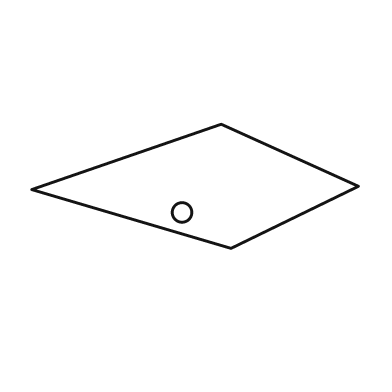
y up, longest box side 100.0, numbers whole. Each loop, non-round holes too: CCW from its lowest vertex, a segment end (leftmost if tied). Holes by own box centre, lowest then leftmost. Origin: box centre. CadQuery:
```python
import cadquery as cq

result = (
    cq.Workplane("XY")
    .moveTo(11.0, -19.0)
    .lineTo(50.0, 0.0)
    .lineTo(8.0, 19.0)
    .lineTo(-50.0, -1.0)
    .close()
    .moveTo(-4.0, -8.0)
    .circle(3.0)
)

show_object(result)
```